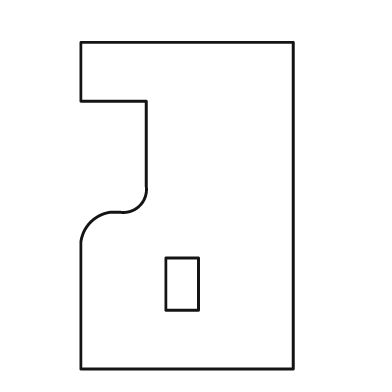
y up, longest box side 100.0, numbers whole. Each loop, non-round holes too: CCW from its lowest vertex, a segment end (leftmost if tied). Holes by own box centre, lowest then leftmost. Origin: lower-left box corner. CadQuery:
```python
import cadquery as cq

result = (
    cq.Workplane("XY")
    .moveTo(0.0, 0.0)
    .lineTo(65.0, 0.0)
    .lineTo(65.0, 100.0)
    .lineTo(0.0, 100.0)
    .lineTo(0.0, 82.0)
    .lineTo(20.0, 82.0)
    .lineTo(20.0, 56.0)
    .threePointArc((18.0, 50.0), (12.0, 48.0))
    .lineTo(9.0, 48.0)
    .threePointArc((3.0, 45.0), (0.0, 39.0))
    .close()
    .moveTo(26.0, 18.0)
    .lineTo(36.0, 18.0)
    .lineTo(36.0, 34.0)
    .lineTo(26.0, 34.0)
    .close()
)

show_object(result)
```